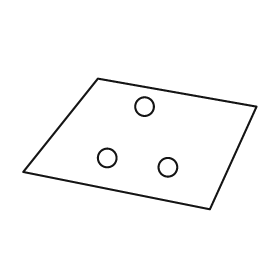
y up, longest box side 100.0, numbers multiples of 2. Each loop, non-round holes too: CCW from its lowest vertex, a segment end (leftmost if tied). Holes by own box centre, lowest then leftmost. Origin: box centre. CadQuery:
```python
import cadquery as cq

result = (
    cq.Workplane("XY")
    .moveTo(30.0, -28.0)
    .lineTo(50.0, 16.0)
    .lineTo(-18.0, 28.0)
    .lineTo(-50.0, -12.0)
    .close()
    .moveTo(12.0, -10.0)
    .circle(4.0)
    .moveTo(-14.0, -6.0)
    .circle(4.0)
    .moveTo(2.0, 16.0)
    .circle(4.0)
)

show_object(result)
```